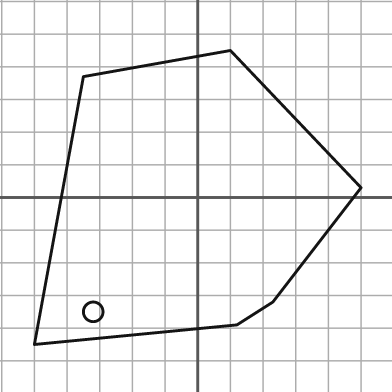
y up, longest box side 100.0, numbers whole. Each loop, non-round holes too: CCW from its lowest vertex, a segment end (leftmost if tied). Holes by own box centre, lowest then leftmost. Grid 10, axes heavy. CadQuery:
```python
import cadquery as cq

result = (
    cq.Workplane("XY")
    .moveTo(-50.0, -45.0)
    .lineTo(12.0, -39.0)
    .lineTo(23.0, -32.0)
    .lineTo(50.0, 3.0)
    .lineTo(10.0, 45.0)
    .lineTo(-35.0, 37.0)
    .close()
    .moveTo(-32.0, -35.0)
    .circle(3.0)
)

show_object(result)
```